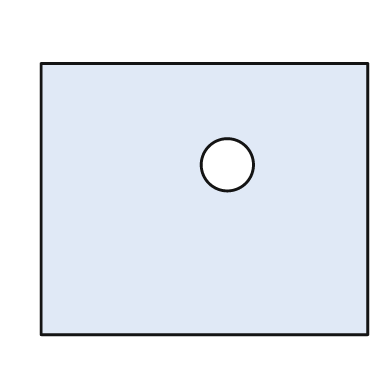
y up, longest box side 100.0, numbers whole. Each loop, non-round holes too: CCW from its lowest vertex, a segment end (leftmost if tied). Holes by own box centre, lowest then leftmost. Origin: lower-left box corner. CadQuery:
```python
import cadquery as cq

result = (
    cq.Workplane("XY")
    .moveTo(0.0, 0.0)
    .lineTo(100.0, 0.0)
    .lineTo(100.0, 83.0)
    .lineTo(0.0, 83.0)
    .close()
    .moveTo(57.0, 52.0)
    .circle(8.0)
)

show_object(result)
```